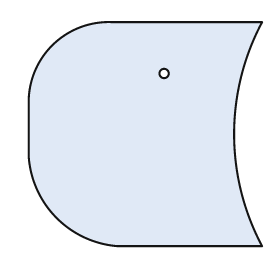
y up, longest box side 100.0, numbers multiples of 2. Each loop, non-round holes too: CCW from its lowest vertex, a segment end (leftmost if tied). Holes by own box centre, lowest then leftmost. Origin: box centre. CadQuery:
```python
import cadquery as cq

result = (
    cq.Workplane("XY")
    .moveTo(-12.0, -48.0)
    .lineTo(50.0, -48.0)
    .threePointArc((38.0, 0.0), (50.0, 48.0))
    .lineTo(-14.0, 48.0)
    .threePointArc((-40.0, 38.0), (-50.0, 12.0))
    .lineTo(-50.0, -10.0)
    .threePointArc((-38.0, -36.0), (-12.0, -48.0))
    .close()
    .moveTo(8.0, 26.0)
    .circle(2.0)
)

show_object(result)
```